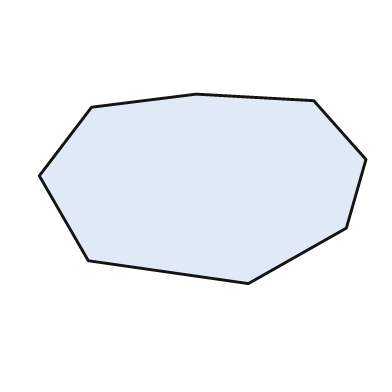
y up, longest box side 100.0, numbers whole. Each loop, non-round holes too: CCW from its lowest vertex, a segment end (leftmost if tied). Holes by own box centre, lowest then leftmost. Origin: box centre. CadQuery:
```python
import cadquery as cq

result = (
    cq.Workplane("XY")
    .moveTo(14.0, -29.0)
    .lineTo(44.0, -12.0)
    .lineTo(50.0, 9.0)
    .lineTo(34.0, 27.0)
    .lineTo(-2.0, 29.0)
    .lineTo(-34.0, 25.0)
    .lineTo(-50.0, 4.0)
    .lineTo(-35.0, -22.0)
    .close()
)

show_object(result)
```